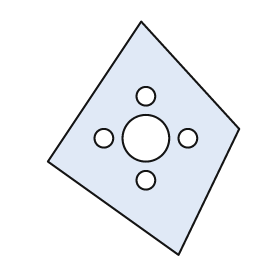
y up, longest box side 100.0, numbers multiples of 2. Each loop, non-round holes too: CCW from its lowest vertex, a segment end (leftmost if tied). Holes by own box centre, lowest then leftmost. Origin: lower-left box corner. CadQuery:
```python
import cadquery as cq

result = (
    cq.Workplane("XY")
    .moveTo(56.0, 0.0)
    .lineTo(82.0, 54.0)
    .lineTo(40.0, 100.0)
    .lineTo(0.0, 40.0)
    .close()
    .moveTo(42.0, 32.0)
    .circle(4.0)
    .moveTo(24.0, 50.0)
    .circle(4.0)
    .moveTo(42.0, 50.0)
    .circle(10.0)
    .moveTo(60.0, 50.0)
    .circle(4.0)
    .moveTo(42.0, 68.0)
    .circle(4.0)
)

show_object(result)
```